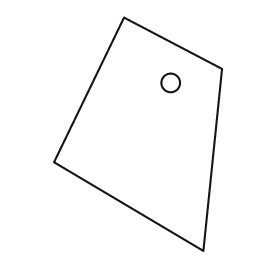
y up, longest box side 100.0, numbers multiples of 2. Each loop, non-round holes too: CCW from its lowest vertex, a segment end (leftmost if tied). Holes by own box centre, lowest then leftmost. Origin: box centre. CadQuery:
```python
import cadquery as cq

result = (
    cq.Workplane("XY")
    .moveTo(28.0, -50.0)
    .lineTo(36.0, 28.0)
    .lineTo(-6.0, 50.0)
    .lineTo(-36.0, -12.0)
    .close()
    .moveTo(14.0, 22.0)
    .circle(4.0)
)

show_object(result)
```